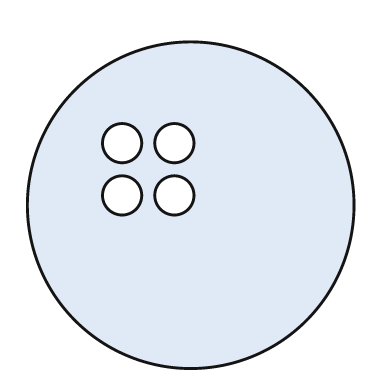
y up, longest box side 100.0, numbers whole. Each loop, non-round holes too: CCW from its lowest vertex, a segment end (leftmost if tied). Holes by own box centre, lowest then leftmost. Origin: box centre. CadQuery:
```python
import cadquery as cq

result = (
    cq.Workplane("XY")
    .moveTo(0.0, 0.0)
    .circle(50.0)
    .moveTo(-21.0, 3.0)
    .circle(6.0)
    .moveTo(-5.0, 3.0)
    .circle(6.0)
    .moveTo(-21.0, 19.0)
    .circle(6.0)
    .moveTo(-5.0, 19.0)
    .circle(6.0)
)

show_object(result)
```